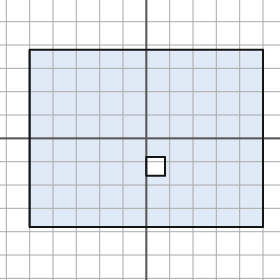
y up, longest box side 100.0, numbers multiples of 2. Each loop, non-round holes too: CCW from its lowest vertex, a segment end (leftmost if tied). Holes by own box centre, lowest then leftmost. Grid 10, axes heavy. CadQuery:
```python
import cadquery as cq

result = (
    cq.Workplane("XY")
    .moveTo(-50.0, -38.0)
    .lineTo(50.0, -38.0)
    .lineTo(50.0, 38.0)
    .lineTo(-50.0, 38.0)
    .close()
    .moveTo(0.0, -16.0)
    .lineTo(8.0, -16.0)
    .lineTo(8.0, -8.0)
    .lineTo(0.0, -8.0)
    .close()
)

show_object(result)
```